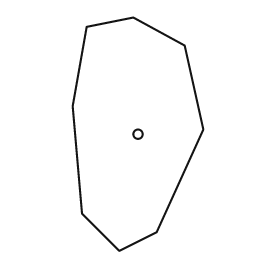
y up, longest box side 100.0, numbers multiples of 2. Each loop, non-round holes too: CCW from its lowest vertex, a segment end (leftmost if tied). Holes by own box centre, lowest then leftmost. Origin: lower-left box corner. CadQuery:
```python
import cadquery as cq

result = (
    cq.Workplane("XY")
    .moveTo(20.0, 0.0)
    .lineTo(36.0, 8.0)
    .lineTo(56.0, 52.0)
    .lineTo(48.0, 88.0)
    .lineTo(26.0, 100.0)
    .lineTo(6.0, 96.0)
    .lineTo(0.0, 62.0)
    .lineTo(4.0, 16.0)
    .close()
    .moveTo(28.0, 50.0)
    .circle(2.0)
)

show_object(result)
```